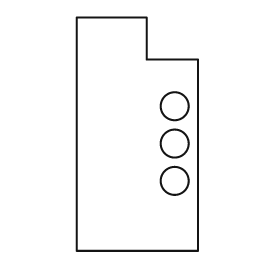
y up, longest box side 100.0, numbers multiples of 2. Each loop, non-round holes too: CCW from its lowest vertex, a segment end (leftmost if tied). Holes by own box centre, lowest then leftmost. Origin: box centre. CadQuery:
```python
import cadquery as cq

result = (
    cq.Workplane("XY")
    .moveTo(-26.0, -50.0)
    .lineTo(26.0, -50.0)
    .lineTo(26.0, 32.0)
    .lineTo(4.0, 32.0)
    .lineTo(4.0, 50.0)
    .lineTo(-26.0, 50.0)
    .close()
    .moveTo(16.0, -20.0)
    .circle(6.0)
    .moveTo(16.0, -4.0)
    .circle(6.0)
    .moveTo(16.0, 12.0)
    .circle(6.0)
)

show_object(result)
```